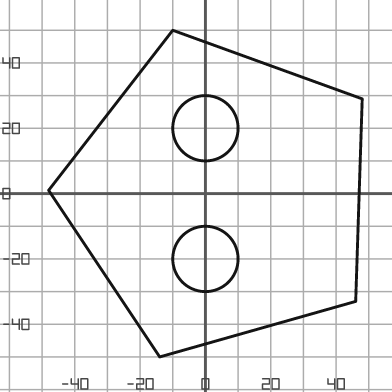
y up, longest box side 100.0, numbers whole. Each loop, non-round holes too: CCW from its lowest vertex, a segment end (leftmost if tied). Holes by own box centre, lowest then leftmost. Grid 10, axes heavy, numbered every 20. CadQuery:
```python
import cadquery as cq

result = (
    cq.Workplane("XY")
    .moveTo(-14.0, -50.0)
    .lineTo(46.0, -33.0)
    .lineTo(48.0, 29.0)
    .lineTo(-10.0, 50.0)
    .lineTo(-48.0, 1.0)
    .close()
    .moveTo(0.0, -20.0)
    .circle(10.0)
    .moveTo(0.0, 20.0)
    .circle(10.0)
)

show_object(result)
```